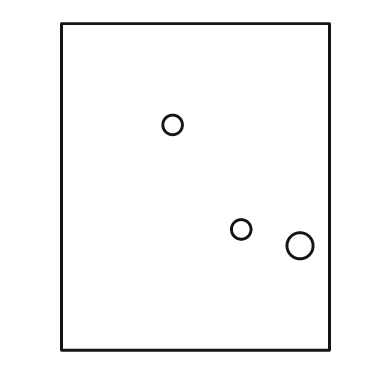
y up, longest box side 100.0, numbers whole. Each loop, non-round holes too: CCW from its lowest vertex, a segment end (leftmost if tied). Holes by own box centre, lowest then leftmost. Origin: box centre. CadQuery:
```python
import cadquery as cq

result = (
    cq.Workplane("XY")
    .moveTo(-41.0, -50.0)
    .lineTo(41.0, -50.0)
    .lineTo(41.0, 50.0)
    .lineTo(-41.0, 50.0)
    .close()
    .moveTo(32.0, -18.0)
    .circle(4.0)
    .moveTo(14.0, -13.0)
    .circle(3.0)
    .moveTo(-7.0, 19.0)
    .circle(3.0)
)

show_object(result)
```